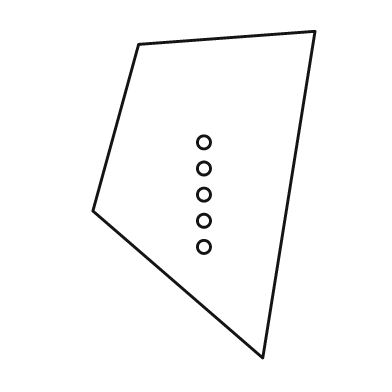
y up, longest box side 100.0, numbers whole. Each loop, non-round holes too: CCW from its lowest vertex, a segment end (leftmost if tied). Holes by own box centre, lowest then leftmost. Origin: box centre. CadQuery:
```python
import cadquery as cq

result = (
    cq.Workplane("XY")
    .moveTo(18.0, -50.0)
    .lineTo(34.0, 50.0)
    .lineTo(-20.0, 46.0)
    .lineTo(-34.0, -5.0)
    .close()
    .moveTo(0.0, -16.0)
    .circle(2.0)
    .moveTo(0.0, -8.0)
    .circle(2.0)
    .moveTo(0.0, 0.0)
    .circle(2.0)
    .moveTo(0.0, 8.0)
    .circle(2.0)
    .moveTo(0.0, 16.0)
    .circle(2.0)
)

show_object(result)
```